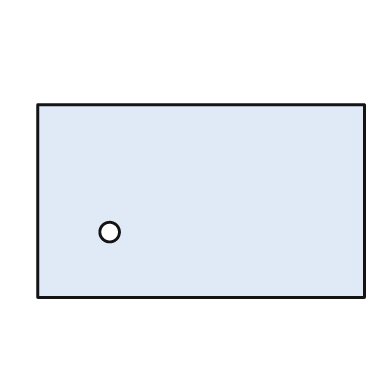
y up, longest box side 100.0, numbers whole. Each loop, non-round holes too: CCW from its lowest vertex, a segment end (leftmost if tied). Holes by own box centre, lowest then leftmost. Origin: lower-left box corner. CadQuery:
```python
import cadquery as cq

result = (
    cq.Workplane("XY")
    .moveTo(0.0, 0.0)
    .lineTo(100.0, 0.0)
    .lineTo(100.0, 59.0)
    .lineTo(0.0, 59.0)
    .close()
    .moveTo(22.0, 20.0)
    .circle(3.0)
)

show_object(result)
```